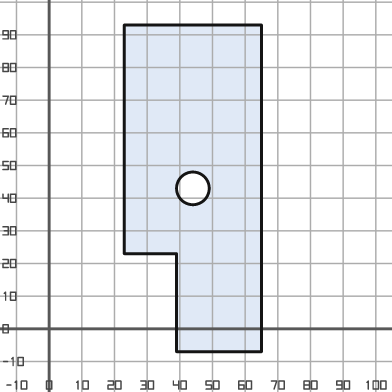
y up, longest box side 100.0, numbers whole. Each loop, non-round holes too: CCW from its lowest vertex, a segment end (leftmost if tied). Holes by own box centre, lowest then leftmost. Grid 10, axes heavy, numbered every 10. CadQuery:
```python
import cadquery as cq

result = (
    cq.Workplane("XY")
    .moveTo(39.0, -7.0)
    .lineTo(65.0, -7.0)
    .lineTo(65.0, 93.0)
    .lineTo(23.0, 93.0)
    .lineTo(23.0, 23.0)
    .lineTo(39.0, 23.0)
    .close()
    .moveTo(44.0, 43.0)
    .circle(5.0)
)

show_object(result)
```